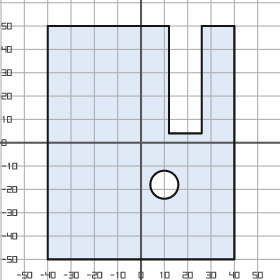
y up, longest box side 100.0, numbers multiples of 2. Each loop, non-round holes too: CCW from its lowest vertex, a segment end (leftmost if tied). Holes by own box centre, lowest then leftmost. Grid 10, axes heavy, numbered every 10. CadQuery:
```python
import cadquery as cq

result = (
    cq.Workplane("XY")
    .moveTo(-40.0, -50.0)
    .lineTo(40.0, -50.0)
    .lineTo(40.0, 50.0)
    .lineTo(26.0, 50.0)
    .lineTo(26.0, 4.0)
    .lineTo(12.0, 4.0)
    .lineTo(12.0, 50.0)
    .lineTo(-40.0, 50.0)
    .close()
    .moveTo(10.0, -18.0)
    .circle(6.0)
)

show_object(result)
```